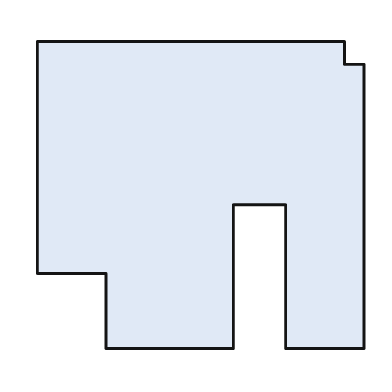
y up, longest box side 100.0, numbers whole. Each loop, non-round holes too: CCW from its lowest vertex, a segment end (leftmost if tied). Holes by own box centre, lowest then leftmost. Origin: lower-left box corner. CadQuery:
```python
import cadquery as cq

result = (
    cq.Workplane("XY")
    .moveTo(21.0, 0.0)
    .lineTo(60.0, 0.0)
    .lineTo(60.0, 44.0)
    .lineTo(76.0, 44.0)
    .lineTo(76.0, 0.0)
    .lineTo(100.0, 0.0)
    .lineTo(100.0, 87.0)
    .lineTo(94.0, 87.0)
    .lineTo(94.0, 94.0)
    .lineTo(0.0, 94.0)
    .lineTo(0.0, 23.0)
    .lineTo(21.0, 23.0)
    .close()
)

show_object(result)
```